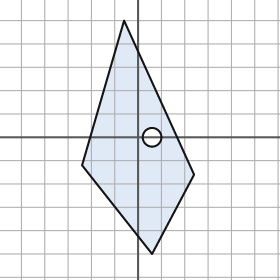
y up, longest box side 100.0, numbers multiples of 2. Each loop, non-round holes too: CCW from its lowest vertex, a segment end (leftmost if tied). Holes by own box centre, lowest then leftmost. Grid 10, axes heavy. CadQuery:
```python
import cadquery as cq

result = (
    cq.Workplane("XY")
    .moveTo(6.0, -50.0)
    .lineTo(24.0, -16.0)
    .lineTo(-6.0, 50.0)
    .lineTo(-24.0, -12.0)
    .close()
    .moveTo(6.0, 0.0)
    .circle(4.0)
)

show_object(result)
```